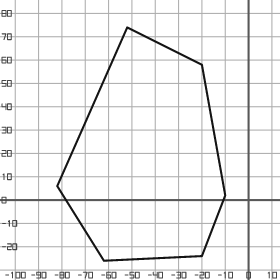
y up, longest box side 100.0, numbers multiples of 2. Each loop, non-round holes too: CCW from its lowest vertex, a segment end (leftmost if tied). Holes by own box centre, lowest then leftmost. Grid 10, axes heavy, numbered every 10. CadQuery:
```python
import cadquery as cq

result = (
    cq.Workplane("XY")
    .moveTo(-62.0, -26.0)
    .lineTo(-20.0, -24.0)
    .lineTo(-10.0, 2.0)
    .lineTo(-20.0, 58.0)
    .lineTo(-52.0, 74.0)
    .lineTo(-82.0, 6.0)
    .close()
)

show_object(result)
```